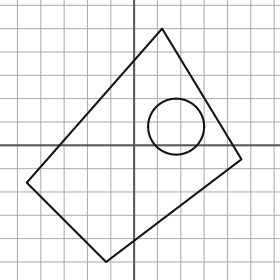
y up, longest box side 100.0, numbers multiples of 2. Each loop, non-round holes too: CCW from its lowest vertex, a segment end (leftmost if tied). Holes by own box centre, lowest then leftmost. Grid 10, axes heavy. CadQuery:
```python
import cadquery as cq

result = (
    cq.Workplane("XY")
    .moveTo(-12.0, -50.0)
    .lineTo(46.0, -6.0)
    .lineTo(12.0, 50.0)
    .lineTo(-46.0, -16.0)
    .close()
    .moveTo(18.0, 8.0)
    .circle(12.0)
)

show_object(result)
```